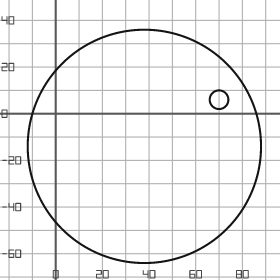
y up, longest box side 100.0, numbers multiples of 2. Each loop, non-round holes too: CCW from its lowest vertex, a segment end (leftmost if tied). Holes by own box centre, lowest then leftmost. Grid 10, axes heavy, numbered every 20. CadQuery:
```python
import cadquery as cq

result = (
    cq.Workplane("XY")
    .moveTo(38.0, -14.0)
    .circle(50.0)
    .moveTo(70.0, 6.0)
    .circle(4.0)
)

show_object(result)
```